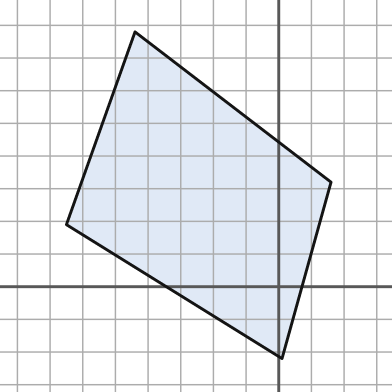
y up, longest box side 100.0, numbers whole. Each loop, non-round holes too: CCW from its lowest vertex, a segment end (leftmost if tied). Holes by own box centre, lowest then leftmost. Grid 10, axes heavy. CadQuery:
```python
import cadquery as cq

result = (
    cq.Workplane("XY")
    .moveTo(1.0, -22.0)
    .lineTo(16.0, 32.0)
    .lineTo(-44.0, 78.0)
    .lineTo(-65.0, 19.0)
    .close()
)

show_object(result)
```